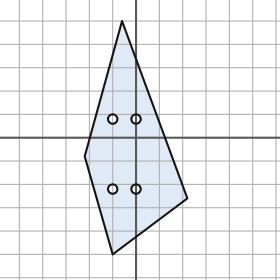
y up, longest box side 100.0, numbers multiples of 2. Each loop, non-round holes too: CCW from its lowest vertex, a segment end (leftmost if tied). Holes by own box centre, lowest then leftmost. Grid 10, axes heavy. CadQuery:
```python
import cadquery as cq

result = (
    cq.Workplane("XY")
    .moveTo(-10.0, -50.0)
    .lineTo(22.0, -26.0)
    .lineTo(-6.0, 50.0)
    .lineTo(-22.0, -8.0)
    .close()
    .moveTo(-10.0, -22.0)
    .circle(2.0)
    .moveTo(0.0, -22.0)
    .circle(2.0)
    .moveTo(-10.0, 8.0)
    .circle(2.0)
    .moveTo(0.0, 8.0)
    .circle(2.0)
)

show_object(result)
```